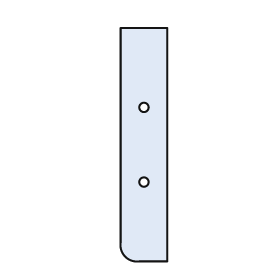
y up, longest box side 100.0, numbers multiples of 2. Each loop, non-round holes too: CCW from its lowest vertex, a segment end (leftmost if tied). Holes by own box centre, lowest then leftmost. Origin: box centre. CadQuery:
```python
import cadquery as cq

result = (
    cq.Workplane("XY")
    .moveTo(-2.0, -50.0)
    .lineTo(10.0, -50.0)
    .lineTo(10.0, 50.0)
    .lineTo(-10.0, 50.0)
    .lineTo(-10.0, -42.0)
    .threePointArc((-8.0, -48.0), (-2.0, -50.0))
    .close()
    .moveTo(0.0, -16.0)
    .circle(2.0)
    .moveTo(0.0, 16.0)
    .circle(2.0)
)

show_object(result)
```